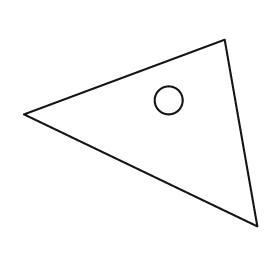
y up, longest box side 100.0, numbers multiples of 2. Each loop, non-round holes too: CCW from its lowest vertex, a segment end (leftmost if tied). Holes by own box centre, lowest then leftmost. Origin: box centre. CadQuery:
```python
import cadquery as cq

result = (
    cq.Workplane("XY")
    .moveTo(50.0, -40.0)
    .lineTo(36.0, 40.0)
    .lineTo(-50.0, 8.0)
    .close()
    .moveTo(12.0, 14.0)
    .circle(6.0)
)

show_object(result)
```